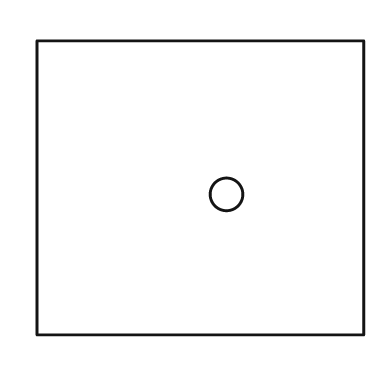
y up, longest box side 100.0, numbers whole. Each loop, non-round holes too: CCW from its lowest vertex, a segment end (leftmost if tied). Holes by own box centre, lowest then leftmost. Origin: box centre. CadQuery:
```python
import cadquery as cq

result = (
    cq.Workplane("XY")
    .moveTo(-50.0, -45.0)
    .lineTo(50.0, -45.0)
    .lineTo(50.0, 45.0)
    .lineTo(-50.0, 45.0)
    .close()
    .moveTo(8.0, -2.0)
    .circle(5.0)
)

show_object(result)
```